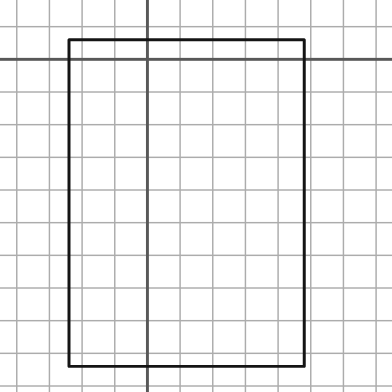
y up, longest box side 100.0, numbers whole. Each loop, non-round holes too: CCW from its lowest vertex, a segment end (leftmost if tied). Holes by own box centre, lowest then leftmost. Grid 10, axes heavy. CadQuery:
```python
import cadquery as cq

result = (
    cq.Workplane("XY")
    .moveTo(-24.0, -94.0)
    .lineTo(48.0, -94.0)
    .lineTo(48.0, 6.0)
    .lineTo(-24.0, 6.0)
    .close()
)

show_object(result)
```